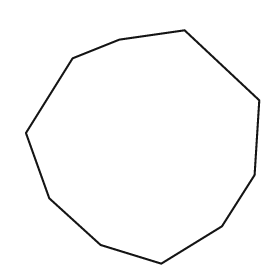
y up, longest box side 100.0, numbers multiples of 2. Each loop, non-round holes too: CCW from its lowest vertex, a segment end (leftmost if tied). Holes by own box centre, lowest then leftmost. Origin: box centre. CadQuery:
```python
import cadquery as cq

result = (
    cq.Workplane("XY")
    .moveTo(8.0, -50.0)
    .lineTo(34.0, -34.0)
    .lineTo(48.0, -12.0)
    .lineTo(50.0, 20.0)
    .lineTo(18.0, 50.0)
    .lineTo(-10.0, 46.0)
    .lineTo(-30.0, 38.0)
    .lineTo(-50.0, 6.0)
    .lineTo(-40.0, -22.0)
    .lineTo(-18.0, -42.0)
    .close()
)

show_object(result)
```